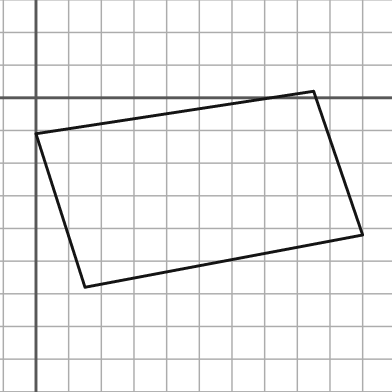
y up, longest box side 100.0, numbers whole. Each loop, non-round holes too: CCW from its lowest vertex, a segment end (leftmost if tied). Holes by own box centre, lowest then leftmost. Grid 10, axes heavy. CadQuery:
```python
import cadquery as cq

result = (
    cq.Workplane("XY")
    .moveTo(15.0, -58.0)
    .lineTo(100.0, -42.0)
    .lineTo(85.0, 2.0)
    .lineTo(0.0, -11.0)
    .close()
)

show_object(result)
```